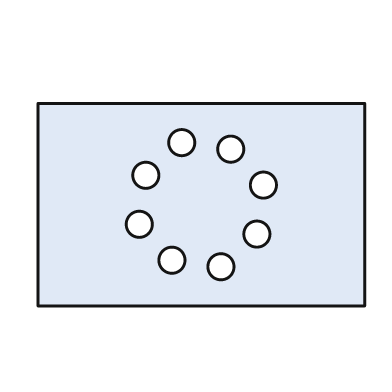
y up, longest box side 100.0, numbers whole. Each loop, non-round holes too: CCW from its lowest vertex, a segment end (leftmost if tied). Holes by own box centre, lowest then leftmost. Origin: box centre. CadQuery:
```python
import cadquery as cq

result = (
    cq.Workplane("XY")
    .moveTo(-50.0, -31.0)
    .lineTo(50.0, -31.0)
    .lineTo(50.0, 31.0)
    .lineTo(-50.0, 31.0)
    .close()
    .moveTo(6.0, -19.0)
    .circle(4.0)
    .moveTo(-9.0, -17.0)
    .circle(4.0)
    .moveTo(17.0, -9.0)
    .circle(4.0)
    .moveTo(-19.0, -6.0)
    .circle(4.0)
    .moveTo(19.0, 6.0)
    .circle(4.0)
    .moveTo(-17.0, 9.0)
    .circle(4.0)
    .moveTo(9.0, 17.0)
    .circle(4.0)
    .moveTo(-6.0, 19.0)
    .circle(4.0)
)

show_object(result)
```